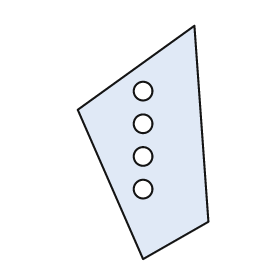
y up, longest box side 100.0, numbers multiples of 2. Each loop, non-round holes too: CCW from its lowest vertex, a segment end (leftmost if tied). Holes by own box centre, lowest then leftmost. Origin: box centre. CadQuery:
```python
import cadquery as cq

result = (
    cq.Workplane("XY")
    .moveTo(0.0, -50.0)
    .lineTo(28.0, -34.0)
    .lineTo(22.0, 50.0)
    .lineTo(-28.0, 14.0)
    .close()
    .moveTo(0.0, -20.0)
    .circle(4.0)
    .moveTo(0.0, -6.0)
    .circle(4.0)
    .moveTo(0.0, 8.0)
    .circle(4.0)
    .moveTo(0.0, 22.0)
    .circle(4.0)
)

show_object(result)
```